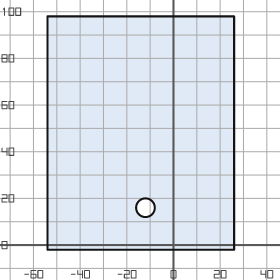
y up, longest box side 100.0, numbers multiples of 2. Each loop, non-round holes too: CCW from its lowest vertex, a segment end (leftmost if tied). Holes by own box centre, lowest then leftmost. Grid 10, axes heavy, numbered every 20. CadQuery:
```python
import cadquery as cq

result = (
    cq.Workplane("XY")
    .moveTo(-54.0, -2.0)
    .lineTo(26.0, -2.0)
    .lineTo(26.0, 98.0)
    .lineTo(-54.0, 98.0)
    .close()
    .moveTo(-12.0, 16.0)
    .circle(4.0)
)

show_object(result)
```